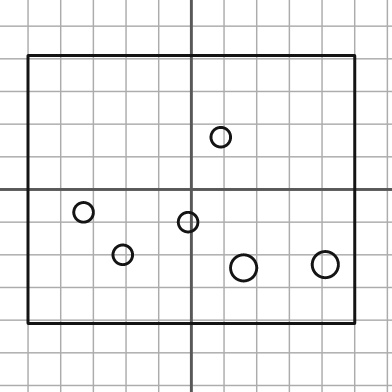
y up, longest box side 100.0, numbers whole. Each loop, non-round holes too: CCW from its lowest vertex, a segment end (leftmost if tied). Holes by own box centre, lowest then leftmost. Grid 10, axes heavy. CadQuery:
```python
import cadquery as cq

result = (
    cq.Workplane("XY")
    .moveTo(-50.0, -41.0)
    .lineTo(50.0, -41.0)
    .lineTo(50.0, 41.0)
    .lineTo(-50.0, 41.0)
    .close()
    .moveTo(16.0, -24.0)
    .circle(4.0)
    .moveTo(41.0, -23.0)
    .circle(4.0)
    .moveTo(-21.0, -20.0)
    .circle(3.0)
    .moveTo(-1.0, -10.0)
    .circle(3.0)
    .moveTo(-33.0, -7.0)
    .circle(3.0)
    .moveTo(9.0, 16.0)
    .circle(3.0)
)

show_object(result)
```